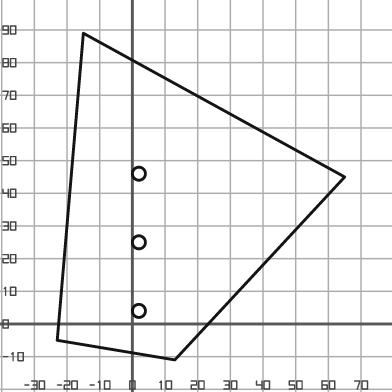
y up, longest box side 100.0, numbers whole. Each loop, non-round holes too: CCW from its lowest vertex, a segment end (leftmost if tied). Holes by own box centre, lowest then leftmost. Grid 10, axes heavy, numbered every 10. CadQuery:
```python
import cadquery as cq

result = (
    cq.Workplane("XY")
    .moveTo(13.0, -11.0)
    .lineTo(65.0, 45.0)
    .lineTo(-15.0, 89.0)
    .lineTo(-23.0, -5.0)
    .close()
    .moveTo(2.0, 4.0)
    .circle(2.0)
    .moveTo(2.0, 25.0)
    .circle(2.0)
    .moveTo(2.0, 46.0)
    .circle(2.0)
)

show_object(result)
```